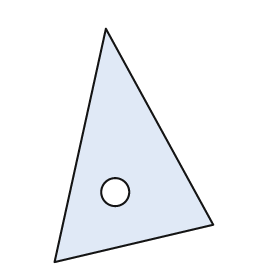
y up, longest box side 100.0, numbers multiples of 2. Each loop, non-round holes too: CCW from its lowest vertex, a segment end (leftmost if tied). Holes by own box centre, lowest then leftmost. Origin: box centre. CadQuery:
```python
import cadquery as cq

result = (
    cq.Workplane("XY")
    .moveTo(-34.0, -50.0)
    .lineTo(34.0, -34.0)
    .lineTo(-12.0, 50.0)
    .close()
    .moveTo(-8.0, -20.0)
    .circle(6.0)
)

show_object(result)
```